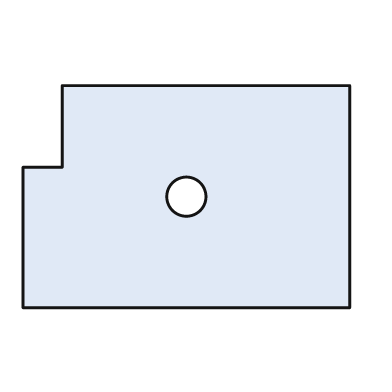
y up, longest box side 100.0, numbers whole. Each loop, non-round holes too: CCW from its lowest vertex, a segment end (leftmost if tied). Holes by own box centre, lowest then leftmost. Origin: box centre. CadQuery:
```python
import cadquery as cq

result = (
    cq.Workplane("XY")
    .moveTo(-50.0, -34.0)
    .lineTo(50.0, -34.0)
    .lineTo(50.0, 34.0)
    .lineTo(-38.0, 34.0)
    .lineTo(-38.0, 9.0)
    .lineTo(-50.0, 9.0)
    .close()
    .moveTo(0.0, 0.0)
    .circle(6.0)
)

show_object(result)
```